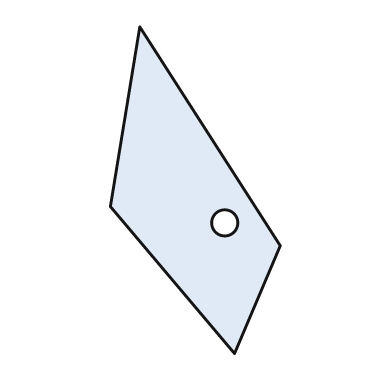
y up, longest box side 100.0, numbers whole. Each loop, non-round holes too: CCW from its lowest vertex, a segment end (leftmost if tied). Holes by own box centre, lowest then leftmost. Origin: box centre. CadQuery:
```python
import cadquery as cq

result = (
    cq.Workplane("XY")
    .moveTo(12.0, -50.0)
    .lineTo(26.0, -17.0)
    .lineTo(-17.0, 50.0)
    .lineTo(-26.0, -5.0)
    .close()
    .moveTo(9.0, -10.0)
    .circle(4.0)
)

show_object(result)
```